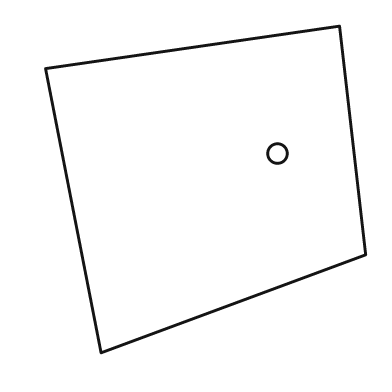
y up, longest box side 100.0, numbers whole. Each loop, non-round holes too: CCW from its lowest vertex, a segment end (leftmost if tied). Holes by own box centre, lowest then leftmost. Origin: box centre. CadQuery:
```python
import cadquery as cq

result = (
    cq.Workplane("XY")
    .moveTo(-32.0, -50.0)
    .lineTo(49.0, -20.0)
    .lineTo(41.0, 50.0)
    .lineTo(-49.0, 37.0)
    .close()
    .moveTo(22.0, 11.0)
    .circle(3.0)
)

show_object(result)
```